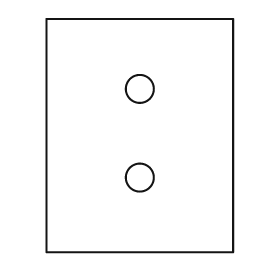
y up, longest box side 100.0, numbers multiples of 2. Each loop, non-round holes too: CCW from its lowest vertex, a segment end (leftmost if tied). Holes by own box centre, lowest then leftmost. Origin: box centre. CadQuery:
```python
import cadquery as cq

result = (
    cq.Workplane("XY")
    .moveTo(-40.0, -50.0)
    .lineTo(40.0, -50.0)
    .lineTo(40.0, 50.0)
    .lineTo(-40.0, 50.0)
    .close()
    .moveTo(0.0, -18.0)
    .circle(6.0)
    .moveTo(0.0, 20.0)
    .circle(6.0)
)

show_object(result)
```